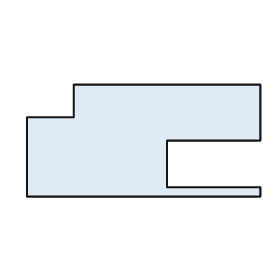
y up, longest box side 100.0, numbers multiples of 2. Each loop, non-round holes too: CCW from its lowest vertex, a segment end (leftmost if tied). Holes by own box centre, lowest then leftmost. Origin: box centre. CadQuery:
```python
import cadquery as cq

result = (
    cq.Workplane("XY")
    .moveTo(-50.0, -24.0)
    .lineTo(50.0, -24.0)
    .lineTo(50.0, -20.0)
    .lineTo(10.0, -20.0)
    .lineTo(10.0, 0.0)
    .lineTo(50.0, 0.0)
    .lineTo(50.0, 24.0)
    .lineTo(-30.0, 24.0)
    .lineTo(-30.0, 10.0)
    .lineTo(-50.0, 10.0)
    .close()
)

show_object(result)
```